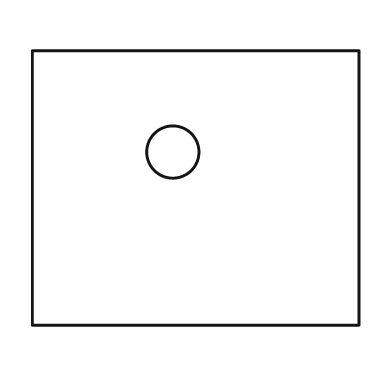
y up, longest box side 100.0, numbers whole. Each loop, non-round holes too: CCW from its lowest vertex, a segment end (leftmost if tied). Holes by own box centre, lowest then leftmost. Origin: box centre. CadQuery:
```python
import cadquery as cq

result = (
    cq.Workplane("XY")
    .moveTo(-50.0, -42.0)
    .lineTo(50.0, -42.0)
    .lineTo(50.0, 42.0)
    .lineTo(-50.0, 42.0)
    .close()
    .moveTo(-7.0, 11.0)
    .circle(8.0)
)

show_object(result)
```